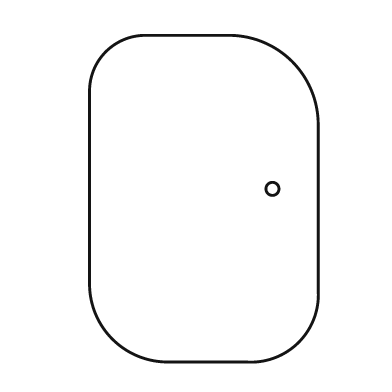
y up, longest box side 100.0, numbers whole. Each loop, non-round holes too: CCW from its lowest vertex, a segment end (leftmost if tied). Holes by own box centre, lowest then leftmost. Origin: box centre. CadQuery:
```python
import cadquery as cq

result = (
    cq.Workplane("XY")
    .moveTo(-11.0, -50.0)
    .lineTo(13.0, -50.0)
    .threePointArc((29.0, -44.0), (35.0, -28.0))
    .lineTo(35.0, 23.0)
    .threePointArc((27.0, 42.0), (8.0, 50.0))
    .lineTo(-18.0, 50.0)
    .threePointArc((-30.0, 45.0), (-35.0, 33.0))
    .lineTo(-35.0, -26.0)
    .threePointArc((-28.0, -43.0), (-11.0, -50.0))
    .close()
    .moveTo(21.0, 3.0)
    .circle(2.0)
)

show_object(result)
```